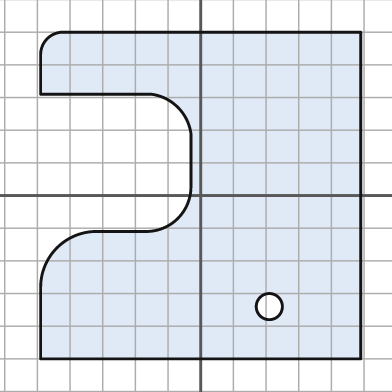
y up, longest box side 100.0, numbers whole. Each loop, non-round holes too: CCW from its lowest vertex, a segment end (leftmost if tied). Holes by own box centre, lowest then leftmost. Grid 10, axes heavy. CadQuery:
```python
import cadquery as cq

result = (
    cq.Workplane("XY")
    .moveTo(-49.0, -50.0)
    .lineTo(49.0, -50.0)
    .lineTo(49.0, 50.0)
    .lineTo(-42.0, 50.0)
    .threePointArc((-47.0, 48.0), (-49.0, 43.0))
    .lineTo(-49.0, 31.0)
    .lineTo(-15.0, 31.0)
    .threePointArc((-7.0, 27.0), (-3.0, 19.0))
    .lineTo(-3.0, 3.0)
    .threePointArc((-7.0, -7.0), (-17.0, -11.0))
    .lineTo(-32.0, -11.0)
    .threePointArc((-44.0, -16.0), (-49.0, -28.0))
    .close()
    .moveTo(21.0, -34.0)
    .circle(4.0)
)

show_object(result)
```